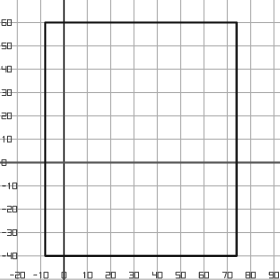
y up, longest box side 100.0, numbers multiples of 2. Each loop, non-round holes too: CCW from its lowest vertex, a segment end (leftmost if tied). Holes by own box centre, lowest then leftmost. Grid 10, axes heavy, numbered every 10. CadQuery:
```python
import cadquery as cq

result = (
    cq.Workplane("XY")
    .moveTo(-8.0, -40.0)
    .lineTo(74.0, -40.0)
    .lineTo(74.0, 60.0)
    .lineTo(-8.0, 60.0)
    .close()
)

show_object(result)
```